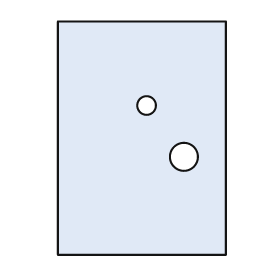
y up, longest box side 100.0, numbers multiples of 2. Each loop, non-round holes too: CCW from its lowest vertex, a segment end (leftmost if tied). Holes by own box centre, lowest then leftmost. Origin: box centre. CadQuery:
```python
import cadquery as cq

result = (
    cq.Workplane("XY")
    .moveTo(-36.0, -50.0)
    .lineTo(36.0, -50.0)
    .lineTo(36.0, 50.0)
    .lineTo(-36.0, 50.0)
    .close()
    .moveTo(18.0, -8.0)
    .circle(6.0)
    .moveTo(2.0, 14.0)
    .circle(4.0)
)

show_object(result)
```